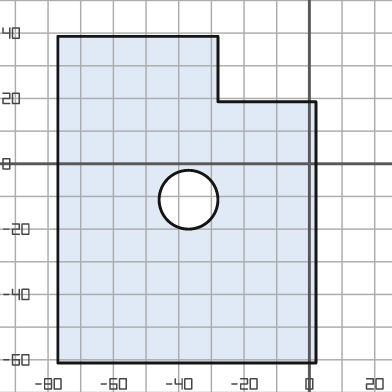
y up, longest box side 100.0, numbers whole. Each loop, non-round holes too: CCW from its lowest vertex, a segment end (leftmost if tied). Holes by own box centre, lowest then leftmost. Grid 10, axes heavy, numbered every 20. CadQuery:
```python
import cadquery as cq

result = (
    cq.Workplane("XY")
    .moveTo(-77.0, -61.0)
    .lineTo(2.0, -61.0)
    .lineTo(2.0, 19.0)
    .lineTo(-28.0, 19.0)
    .lineTo(-28.0, 39.0)
    .lineTo(-77.0, 39.0)
    .close()
    .moveTo(-37.0, -11.0)
    .circle(9.0)
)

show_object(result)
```